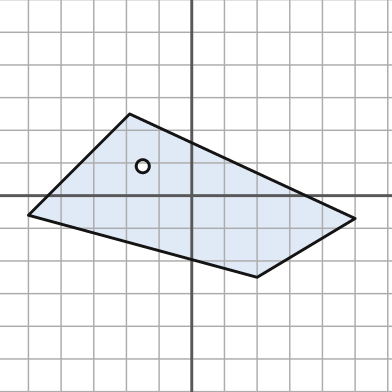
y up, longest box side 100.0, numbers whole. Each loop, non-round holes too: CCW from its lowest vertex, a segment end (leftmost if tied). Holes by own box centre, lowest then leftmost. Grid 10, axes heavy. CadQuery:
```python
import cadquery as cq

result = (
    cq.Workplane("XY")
    .moveTo(20.0, -25.0)
    .lineTo(50.0, -7.0)
    .lineTo(-19.0, 25.0)
    .lineTo(-50.0, -6.0)
    .close()
    .moveTo(-15.0, 9.0)
    .circle(2.0)
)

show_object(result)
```